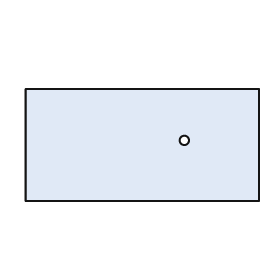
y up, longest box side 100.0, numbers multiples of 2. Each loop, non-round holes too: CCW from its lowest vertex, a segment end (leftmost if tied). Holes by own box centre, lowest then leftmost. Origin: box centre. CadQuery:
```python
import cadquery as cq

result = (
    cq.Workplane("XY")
    .moveTo(-50.0, -24.0)
    .lineTo(50.0, -24.0)
    .lineTo(50.0, 24.0)
    .lineTo(-50.0, 24.0)
    .close()
    .moveTo(18.0, 2.0)
    .circle(2.0)
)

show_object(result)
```